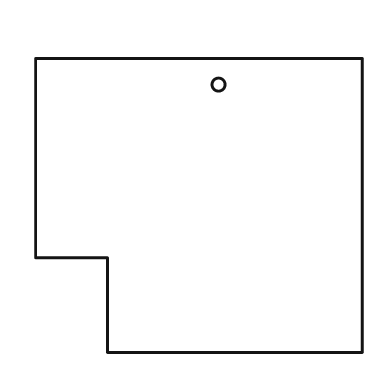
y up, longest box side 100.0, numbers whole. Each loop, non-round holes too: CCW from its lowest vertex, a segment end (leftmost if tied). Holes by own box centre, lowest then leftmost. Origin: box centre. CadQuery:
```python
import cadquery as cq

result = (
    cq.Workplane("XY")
    .moveTo(-28.0, -45.0)
    .lineTo(50.0, -45.0)
    .lineTo(50.0, 45.0)
    .lineTo(-50.0, 45.0)
    .lineTo(-50.0, -16.0)
    .lineTo(-28.0, -16.0)
    .close()
    .moveTo(6.0, 37.0)
    .circle(2.0)
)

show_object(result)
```